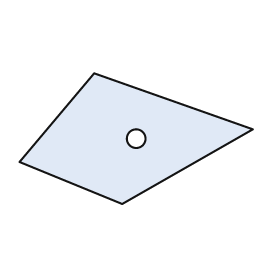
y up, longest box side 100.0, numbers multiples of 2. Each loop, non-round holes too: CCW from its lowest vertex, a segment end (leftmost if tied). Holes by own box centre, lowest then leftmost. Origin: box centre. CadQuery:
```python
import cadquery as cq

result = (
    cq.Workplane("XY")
    .moveTo(-6.0, -28.0)
    .lineTo(50.0, 4.0)
    .lineTo(-18.0, 28.0)
    .lineTo(-50.0, -10.0)
    .close()
    .moveTo(0.0, 0.0)
    .circle(4.0)
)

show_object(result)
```